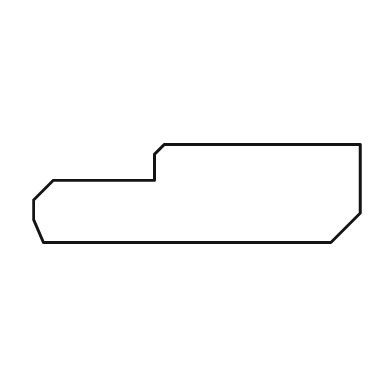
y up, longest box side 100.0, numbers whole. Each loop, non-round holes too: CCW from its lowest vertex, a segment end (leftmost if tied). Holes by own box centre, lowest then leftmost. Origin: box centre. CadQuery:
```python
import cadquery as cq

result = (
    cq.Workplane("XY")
    .moveTo(-47.0, -15.0)
    .lineTo(41.0, -15.0)
    .lineTo(50.0, -6.0)
    .lineTo(50.0, 15.0)
    .lineTo(-10.0, 15.0)
    .lineTo(-13.0, 12.0)
    .lineTo(-13.0, 4.0)
    .lineTo(-44.0, 4.0)
    .lineTo(-50.0, -2.0)
    .lineTo(-50.0, -8.0)
    .close()
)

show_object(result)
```